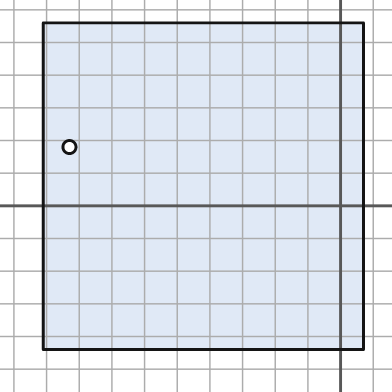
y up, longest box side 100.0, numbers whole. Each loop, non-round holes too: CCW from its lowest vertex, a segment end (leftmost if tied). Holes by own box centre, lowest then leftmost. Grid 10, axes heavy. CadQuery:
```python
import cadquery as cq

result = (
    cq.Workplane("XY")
    .moveTo(-91.0, -44.0)
    .lineTo(7.0, -44.0)
    .lineTo(7.0, 56.0)
    .lineTo(-91.0, 56.0)
    .close()
    .moveTo(-83.0, 18.0)
    .circle(2.0)
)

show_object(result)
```